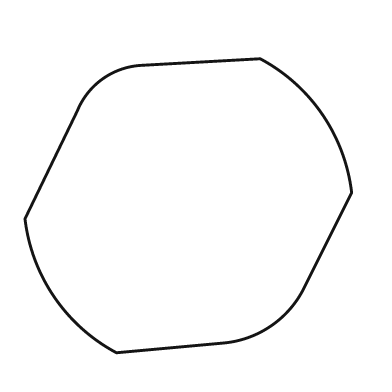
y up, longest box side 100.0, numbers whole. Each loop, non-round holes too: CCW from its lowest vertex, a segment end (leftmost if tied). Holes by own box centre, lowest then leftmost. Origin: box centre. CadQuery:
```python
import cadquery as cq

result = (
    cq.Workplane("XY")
    .moveTo(-22.0, -45.0)
    .lineTo(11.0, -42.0)
    .threePointArc((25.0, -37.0), (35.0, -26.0))
    .lineTo(50.0, 4.0)
    .threePointArc((41.0, 28.0), (22.0, 45.0))
    .lineTo(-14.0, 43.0)
    .threePointArc((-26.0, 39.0), (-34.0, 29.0))
    .lineTo(-50.0, -4.0)
    .threePointArc((-41.0, -28.0), (-22.0, -45.0))
    .close()
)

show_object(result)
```